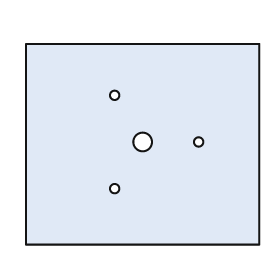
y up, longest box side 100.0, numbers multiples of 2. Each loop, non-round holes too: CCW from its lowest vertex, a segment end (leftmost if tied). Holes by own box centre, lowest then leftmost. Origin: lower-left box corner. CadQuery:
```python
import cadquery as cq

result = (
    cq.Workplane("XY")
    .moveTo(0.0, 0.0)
    .lineTo(100.0, 0.0)
    .lineTo(100.0, 86.0)
    .lineTo(0.0, 86.0)
    .close()
    .moveTo(38.0, 24.0)
    .circle(2.0)
    .moveTo(50.0, 44.0)
    .circle(4.0)
    .moveTo(74.0, 44.0)
    .circle(2.0)
    .moveTo(38.0, 64.0)
    .circle(2.0)
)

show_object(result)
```